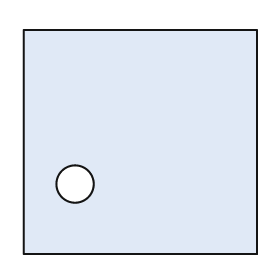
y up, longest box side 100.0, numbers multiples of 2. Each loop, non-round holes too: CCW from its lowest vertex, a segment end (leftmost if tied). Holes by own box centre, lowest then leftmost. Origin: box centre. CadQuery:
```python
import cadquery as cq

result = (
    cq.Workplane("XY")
    .moveTo(-50.0, -48.0)
    .lineTo(50.0, -48.0)
    .lineTo(50.0, 48.0)
    .lineTo(-50.0, 48.0)
    .close()
    .moveTo(-28.0, -18.0)
    .circle(8.0)
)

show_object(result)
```